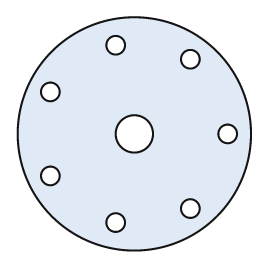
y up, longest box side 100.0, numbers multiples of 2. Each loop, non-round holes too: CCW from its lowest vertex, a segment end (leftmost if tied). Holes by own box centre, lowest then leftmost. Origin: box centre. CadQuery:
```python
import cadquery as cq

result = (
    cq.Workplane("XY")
    .moveTo(0.0, 0.0)
    .circle(50.0)
    .moveTo(-8.0, -38.0)
    .circle(4.0)
    .moveTo(24.0, -32.0)
    .circle(4.0)
    .moveTo(-36.0, -18.0)
    .circle(4.0)
    .moveTo(0.0, 0.0)
    .circle(8.0)
    .moveTo(40.0, 0.0)
    .circle(4.0)
    .moveTo(-36.0, 18.0)
    .circle(4.0)
    .moveTo(24.0, 32.0)
    .circle(4.0)
    .moveTo(-8.0, 38.0)
    .circle(4.0)
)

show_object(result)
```